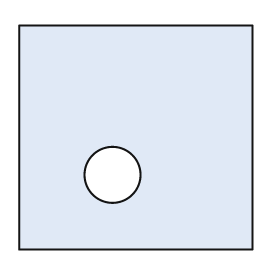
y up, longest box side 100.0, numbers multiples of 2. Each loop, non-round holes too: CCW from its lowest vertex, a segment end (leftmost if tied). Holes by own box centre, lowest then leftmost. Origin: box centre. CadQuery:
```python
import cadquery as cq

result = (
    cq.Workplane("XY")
    .moveTo(-50.0, -48.0)
    .lineTo(50.0, -48.0)
    .lineTo(50.0, 48.0)
    .lineTo(-50.0, 48.0)
    .close()
    .moveTo(-10.0, -16.0)
    .circle(12.0)
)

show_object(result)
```